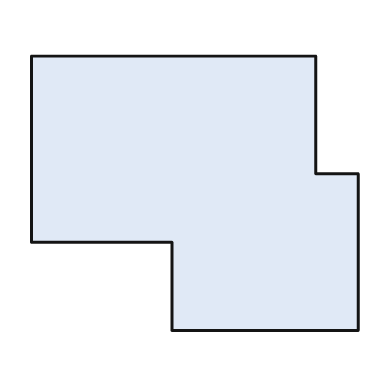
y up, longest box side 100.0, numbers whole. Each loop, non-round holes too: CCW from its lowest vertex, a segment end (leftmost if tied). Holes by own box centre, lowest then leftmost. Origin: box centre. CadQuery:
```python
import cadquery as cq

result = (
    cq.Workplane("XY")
    .moveTo(-7.0, -42.0)
    .lineTo(50.0, -42.0)
    .lineTo(50.0, 6.0)
    .lineTo(37.0, 6.0)
    .lineTo(37.0, 42.0)
    .lineTo(-50.0, 42.0)
    .lineTo(-50.0, -15.0)
    .lineTo(-7.0, -15.0)
    .close()
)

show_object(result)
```